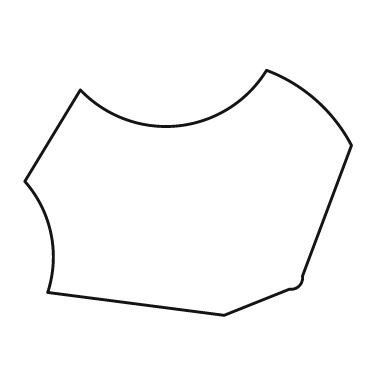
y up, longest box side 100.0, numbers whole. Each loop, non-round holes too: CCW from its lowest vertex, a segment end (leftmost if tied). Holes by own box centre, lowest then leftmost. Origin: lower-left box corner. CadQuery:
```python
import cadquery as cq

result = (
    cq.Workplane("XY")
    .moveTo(61.0, 0.0)
    .lineTo(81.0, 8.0)
    .threePointArc((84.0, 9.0), (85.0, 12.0))
    .lineTo(100.0, 52.0)
    .threePointArc((89.0, 66.0), (74.0, 75.0))
    .threePointArc((47.0, 58.0), (17.0, 69.0))
    .lineTo(0.0, 41.0)
    .threePointArc((8.0, 25.0), (7.0, 7.0))
    .close()
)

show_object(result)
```